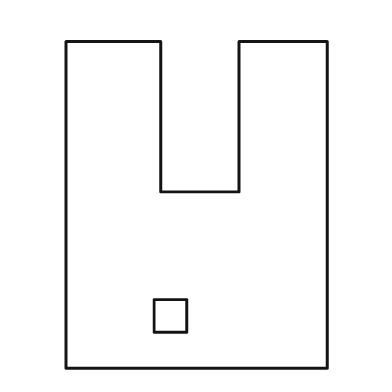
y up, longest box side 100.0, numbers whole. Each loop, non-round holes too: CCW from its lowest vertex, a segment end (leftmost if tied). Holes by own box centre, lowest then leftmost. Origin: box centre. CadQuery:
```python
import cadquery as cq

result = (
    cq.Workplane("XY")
    .moveTo(-40.0, -50.0)
    .lineTo(40.0, -50.0)
    .lineTo(40.0, 50.0)
    .lineTo(13.0, 50.0)
    .lineTo(13.0, 4.0)
    .lineTo(-11.0, 4.0)
    .lineTo(-11.0, 50.0)
    .lineTo(-40.0, 50.0)
    .close()
    .moveTo(-13.0, -39.0)
    .lineTo(-3.0, -39.0)
    .lineTo(-3.0, -29.0)
    .lineTo(-13.0, -29.0)
    .close()
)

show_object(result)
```